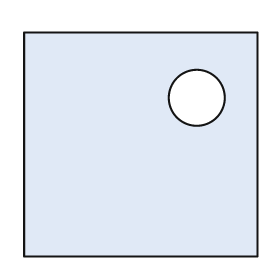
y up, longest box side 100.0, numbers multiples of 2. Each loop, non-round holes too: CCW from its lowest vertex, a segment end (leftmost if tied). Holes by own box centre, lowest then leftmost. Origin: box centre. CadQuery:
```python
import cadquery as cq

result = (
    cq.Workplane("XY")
    .moveTo(-50.0, -48.0)
    .lineTo(50.0, -48.0)
    .lineTo(50.0, 48.0)
    .lineTo(-50.0, 48.0)
    .close()
    .moveTo(24.0, 20.0)
    .circle(12.0)
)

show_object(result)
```